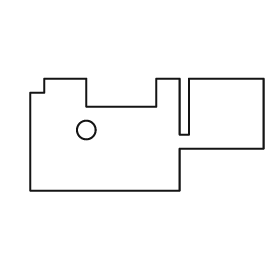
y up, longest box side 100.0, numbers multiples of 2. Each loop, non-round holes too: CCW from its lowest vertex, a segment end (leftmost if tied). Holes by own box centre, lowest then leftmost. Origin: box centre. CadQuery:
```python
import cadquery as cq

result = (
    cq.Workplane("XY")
    .moveTo(-50.0, -24.0)
    .lineTo(14.0, -24.0)
    .lineTo(14.0, -6.0)
    .lineTo(50.0, -6.0)
    .lineTo(50.0, 24.0)
    .lineTo(18.0, 24.0)
    .lineTo(18.0, 0.0)
    .lineTo(14.0, 0.0)
    .lineTo(14.0, 24.0)
    .lineTo(4.0, 24.0)
    .lineTo(4.0, 12.0)
    .lineTo(-26.0, 12.0)
    .lineTo(-26.0, 24.0)
    .lineTo(-44.0, 24.0)
    .lineTo(-44.0, 18.0)
    .lineTo(-50.0, 18.0)
    .close()
    .moveTo(-26.0, 2.0)
    .circle(4.0)
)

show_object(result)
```